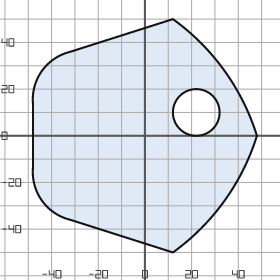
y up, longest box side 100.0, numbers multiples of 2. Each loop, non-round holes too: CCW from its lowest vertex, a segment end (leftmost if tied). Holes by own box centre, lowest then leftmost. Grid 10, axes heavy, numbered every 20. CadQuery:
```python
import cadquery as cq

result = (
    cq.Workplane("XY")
    .moveTo(12.0, -50.0)
    .threePointArc((34.0, -28.0), (48.0, 0.0))
    .threePointArc((34.0, 28.0), (12.0, 50.0))
    .lineTo(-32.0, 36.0)
    .threePointArc((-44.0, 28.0), (-48.0, 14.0))
    .lineTo(-48.0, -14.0)
    .threePointArc((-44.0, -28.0), (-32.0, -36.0))
    .close()
    .moveTo(22.0, 10.0)
    .circle(10.0)
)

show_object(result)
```